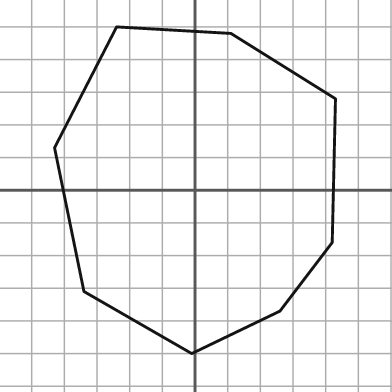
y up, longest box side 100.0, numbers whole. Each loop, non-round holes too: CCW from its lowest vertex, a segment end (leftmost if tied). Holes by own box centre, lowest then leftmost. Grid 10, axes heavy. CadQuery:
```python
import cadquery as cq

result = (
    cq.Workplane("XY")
    .moveTo(-1.0, -50.0)
    .lineTo(26.0, -37.0)
    .lineTo(42.0, -16.0)
    .lineTo(43.0, 28.0)
    .lineTo(11.0, 48.0)
    .lineTo(-24.0, 50.0)
    .lineTo(-43.0, 13.0)
    .lineTo(-34.0, -31.0)
    .close()
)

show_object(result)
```